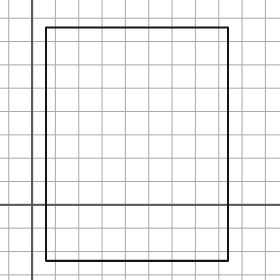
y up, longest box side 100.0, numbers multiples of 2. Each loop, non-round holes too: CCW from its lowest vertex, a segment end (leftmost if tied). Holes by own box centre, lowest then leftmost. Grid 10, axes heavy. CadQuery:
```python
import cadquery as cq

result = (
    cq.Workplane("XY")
    .moveTo(6.0, -24.0)
    .lineTo(84.0, -24.0)
    .lineTo(84.0, 76.0)
    .lineTo(6.0, 76.0)
    .close()
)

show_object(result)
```